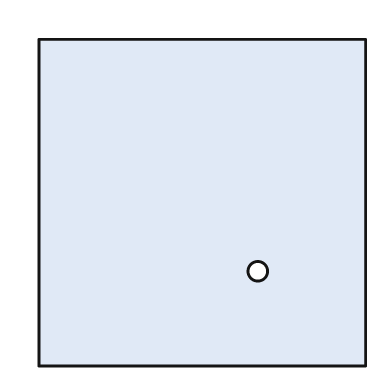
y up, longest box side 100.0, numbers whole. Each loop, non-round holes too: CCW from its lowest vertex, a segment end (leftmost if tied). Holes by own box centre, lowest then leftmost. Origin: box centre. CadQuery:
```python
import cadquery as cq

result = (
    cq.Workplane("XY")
    .moveTo(-50.0, -50.0)
    .lineTo(50.0, -50.0)
    .lineTo(50.0, 50.0)
    .lineTo(-50.0, 50.0)
    .close()
    .moveTo(17.0, -21.0)
    .circle(3.0)
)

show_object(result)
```